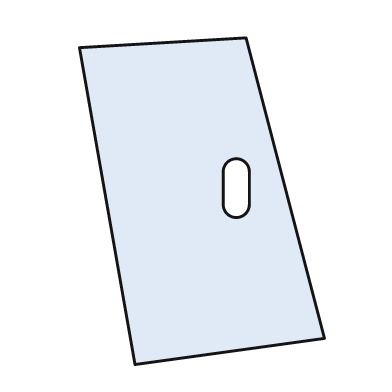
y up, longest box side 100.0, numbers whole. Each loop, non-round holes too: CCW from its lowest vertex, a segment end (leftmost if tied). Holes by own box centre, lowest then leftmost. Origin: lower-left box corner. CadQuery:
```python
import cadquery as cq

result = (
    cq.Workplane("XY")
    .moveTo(17.0, 0.0)
    .lineTo(75.0, 8.0)
    .lineTo(51.0, 100.0)
    .lineTo(0.0, 97.0)
    .close()
    .moveTo(44.0, 49.0)
    .threePointArc((48.0, 45.0), (52.0, 49.0))
    .lineTo(52.0, 59.0)
    .threePointArc((48.0, 63.0), (44.0, 59.0))
    .close()
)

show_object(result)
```